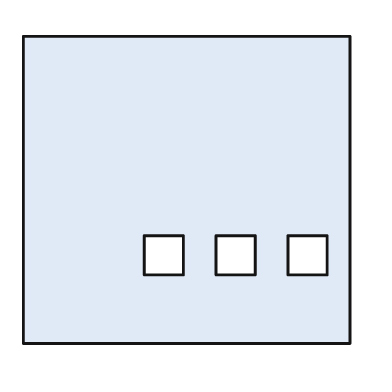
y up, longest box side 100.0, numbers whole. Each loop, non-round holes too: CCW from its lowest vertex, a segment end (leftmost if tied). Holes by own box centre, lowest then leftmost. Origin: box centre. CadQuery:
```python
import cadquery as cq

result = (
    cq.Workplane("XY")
    .moveTo(-50.0, -47.0)
    .lineTo(50.0, -47.0)
    .lineTo(50.0, 47.0)
    .lineTo(-50.0, 47.0)
    .close()
    .moveTo(-13.0, -26.0)
    .lineTo(-1.0, -26.0)
    .lineTo(-1.0, -14.0)
    .lineTo(-13.0, -14.0)
    .close()
    .moveTo(9.0, -26.0)
    .lineTo(21.0, -26.0)
    .lineTo(21.0, -14.0)
    .lineTo(9.0, -14.0)
    .close()
    .moveTo(31.0, -26.0)
    .lineTo(43.0, -26.0)
    .lineTo(43.0, -14.0)
    .lineTo(31.0, -14.0)
    .close()
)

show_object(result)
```